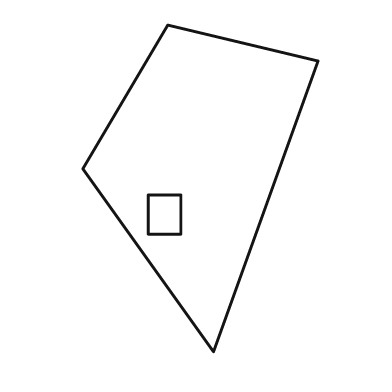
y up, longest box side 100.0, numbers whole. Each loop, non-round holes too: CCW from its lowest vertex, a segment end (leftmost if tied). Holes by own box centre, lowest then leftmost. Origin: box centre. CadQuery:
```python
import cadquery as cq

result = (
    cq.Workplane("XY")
    .moveTo(4.0, -50.0)
    .lineTo(36.0, 39.0)
    .lineTo(-10.0, 50.0)
    .lineTo(-36.0, 6.0)
    .close()
    .moveTo(-16.0, -14.0)
    .lineTo(-6.0, -14.0)
    .lineTo(-6.0, -2.0)
    .lineTo(-16.0, -2.0)
    .close()
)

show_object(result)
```